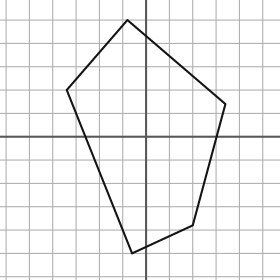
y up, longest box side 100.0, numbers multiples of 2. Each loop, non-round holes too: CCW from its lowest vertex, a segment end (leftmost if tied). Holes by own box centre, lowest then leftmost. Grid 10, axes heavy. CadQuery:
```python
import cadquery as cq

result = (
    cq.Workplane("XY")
    .moveTo(-6.0, -50.0)
    .lineTo(20.0, -38.0)
    .lineTo(34.0, 14.0)
    .lineTo(-8.0, 50.0)
    .lineTo(-34.0, 20.0)
    .close()
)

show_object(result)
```